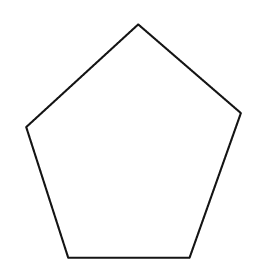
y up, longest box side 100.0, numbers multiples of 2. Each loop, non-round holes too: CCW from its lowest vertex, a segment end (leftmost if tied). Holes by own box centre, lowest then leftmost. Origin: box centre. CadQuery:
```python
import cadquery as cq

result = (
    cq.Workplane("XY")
    .moveTo(-28.0, -50.0)
    .lineTo(24.0, -50.0)
    .lineTo(46.0, 12.0)
    .lineTo(2.0, 50.0)
    .lineTo(-46.0, 6.0)
    .close()
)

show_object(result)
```